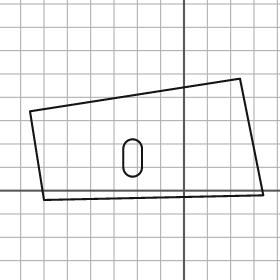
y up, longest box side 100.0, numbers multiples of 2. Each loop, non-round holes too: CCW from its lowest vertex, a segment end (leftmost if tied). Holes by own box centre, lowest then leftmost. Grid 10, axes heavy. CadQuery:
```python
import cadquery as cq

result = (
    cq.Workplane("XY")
    .moveTo(-60.0, -4.0)
    .lineTo(34.0, -2.0)
    .lineTo(24.0, 48.0)
    .lineTo(-66.0, 34.0)
    .close()
    .moveTo(-26.0, 10.0)
    .threePointArc((-22.0, 6.0), (-18.0, 10.0))
    .lineTo(-18.0, 18.0)
    .threePointArc((-22.0, 22.0), (-26.0, 18.0))
    .close()
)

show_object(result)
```